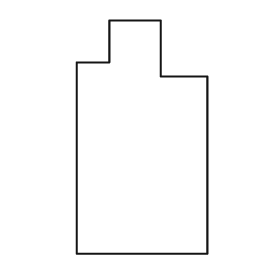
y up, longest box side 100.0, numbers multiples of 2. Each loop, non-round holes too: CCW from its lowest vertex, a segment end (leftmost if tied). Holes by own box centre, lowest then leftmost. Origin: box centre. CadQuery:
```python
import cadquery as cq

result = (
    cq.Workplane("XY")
    .moveTo(-28.0, -50.0)
    .lineTo(28.0, -50.0)
    .lineTo(28.0, 26.0)
    .lineTo(8.0, 26.0)
    .lineTo(8.0, 50.0)
    .lineTo(-14.0, 50.0)
    .lineTo(-14.0, 32.0)
    .lineTo(-28.0, 32.0)
    .close()
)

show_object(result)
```